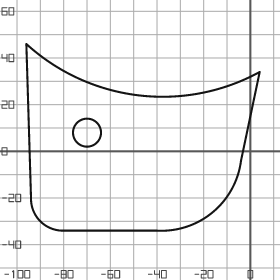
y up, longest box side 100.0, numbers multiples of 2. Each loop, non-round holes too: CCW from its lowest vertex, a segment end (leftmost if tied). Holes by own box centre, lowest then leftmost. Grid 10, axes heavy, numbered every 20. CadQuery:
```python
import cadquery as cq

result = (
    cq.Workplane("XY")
    .moveTo(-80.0, -34.0)
    .lineTo(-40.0, -34.0)
    .threePointArc((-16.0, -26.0), (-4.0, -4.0))
    .lineTo(4.0, 34.0)
    .threePointArc((-48.0, 24.0), (-96.0, 46.0))
    .lineTo(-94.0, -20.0)
    .threePointArc((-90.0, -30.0), (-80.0, -34.0))
    .close()
    .moveTo(-70.0, 8.0)
    .circle(6.0)
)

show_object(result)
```